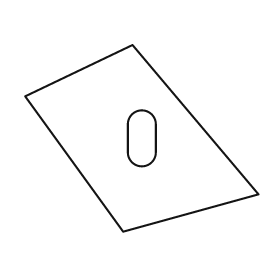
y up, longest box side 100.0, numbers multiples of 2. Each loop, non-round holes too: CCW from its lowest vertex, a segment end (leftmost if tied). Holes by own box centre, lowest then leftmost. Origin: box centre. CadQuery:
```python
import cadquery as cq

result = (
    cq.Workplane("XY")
    .moveTo(-8.0, -40.0)
    .lineTo(50.0, -24.0)
    .lineTo(-4.0, 40.0)
    .lineTo(-50.0, 18.0)
    .close()
    .moveTo(-6.0, -6.0)
    .threePointArc((0.0, -12.0), (6.0, -6.0))
    .lineTo(6.0, 6.0)
    .threePointArc((0.0, 12.0), (-6.0, 6.0))
    .close()
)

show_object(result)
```